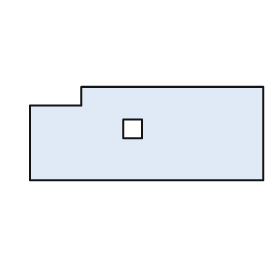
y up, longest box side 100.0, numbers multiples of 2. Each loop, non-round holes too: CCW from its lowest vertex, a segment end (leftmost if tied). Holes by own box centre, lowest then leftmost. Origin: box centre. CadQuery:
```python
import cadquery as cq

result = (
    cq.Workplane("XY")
    .moveTo(-50.0, -20.0)
    .lineTo(50.0, -20.0)
    .lineTo(50.0, 20.0)
    .lineTo(-28.0, 20.0)
    .lineTo(-28.0, 12.0)
    .lineTo(-50.0, 12.0)
    .close()
    .moveTo(-10.0, -2.0)
    .lineTo(-2.0, -2.0)
    .lineTo(-2.0, 6.0)
    .lineTo(-10.0, 6.0)
    .close()
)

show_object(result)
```